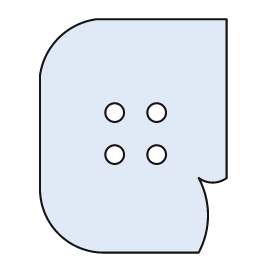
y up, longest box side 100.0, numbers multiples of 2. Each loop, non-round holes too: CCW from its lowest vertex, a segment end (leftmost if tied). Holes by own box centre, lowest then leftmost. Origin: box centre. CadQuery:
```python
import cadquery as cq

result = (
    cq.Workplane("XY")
    .moveTo(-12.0, -50.0)
    .lineTo(28.0, -50.0)
    .threePointArc((32.0, -34.0), (28.0, -18.0))
    .threePointArc((34.0, -20.0), (40.0, -18.0))
    .lineTo(40.0, 50.0)
    .lineTo(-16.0, 50.0)
    .threePointArc((-32.0, 42.0), (-40.0, 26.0))
    .lineTo(-40.0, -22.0)
    .threePointArc((-32.0, -42.0), (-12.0, -50.0))
    .close()
    .moveTo(-8.0, -8.0)
    .circle(4.0)
    .moveTo(10.0, -8.0)
    .circle(4.0)
    .moveTo(-8.0, 10.0)
    .circle(4.0)
    .moveTo(10.0, 10.0)
    .circle(4.0)
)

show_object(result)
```